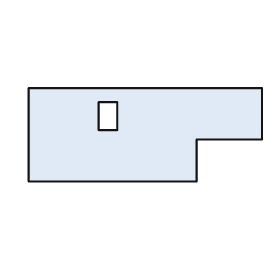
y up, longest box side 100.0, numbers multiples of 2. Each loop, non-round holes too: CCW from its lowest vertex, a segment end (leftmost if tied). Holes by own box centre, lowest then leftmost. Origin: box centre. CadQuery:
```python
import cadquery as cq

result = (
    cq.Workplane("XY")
    .moveTo(-50.0, -20.0)
    .lineTo(22.0, -20.0)
    .lineTo(22.0, -2.0)
    .lineTo(50.0, -2.0)
    .lineTo(50.0, 20.0)
    .lineTo(-50.0, 20.0)
    .close()
    .moveTo(-20.0, 2.0)
    .lineTo(-12.0, 2.0)
    .lineTo(-12.0, 14.0)
    .lineTo(-20.0, 14.0)
    .close()
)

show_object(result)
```